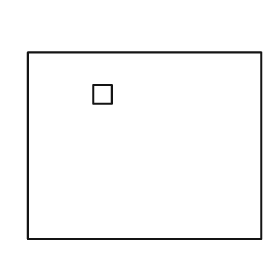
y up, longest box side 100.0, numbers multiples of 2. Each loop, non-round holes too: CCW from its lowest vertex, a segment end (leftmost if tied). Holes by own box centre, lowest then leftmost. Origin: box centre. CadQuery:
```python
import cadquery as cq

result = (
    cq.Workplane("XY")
    .moveTo(-50.0, -40.0)
    .lineTo(50.0, -40.0)
    .lineTo(50.0, 40.0)
    .lineTo(-50.0, 40.0)
    .close()
    .moveTo(-22.0, 18.0)
    .lineTo(-14.0, 18.0)
    .lineTo(-14.0, 26.0)
    .lineTo(-22.0, 26.0)
    .close()
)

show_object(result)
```